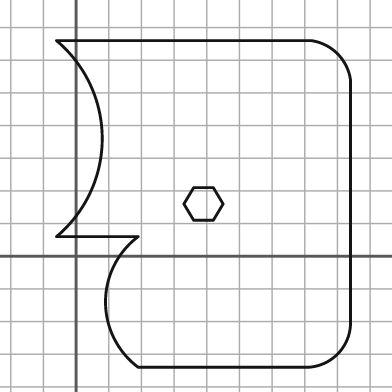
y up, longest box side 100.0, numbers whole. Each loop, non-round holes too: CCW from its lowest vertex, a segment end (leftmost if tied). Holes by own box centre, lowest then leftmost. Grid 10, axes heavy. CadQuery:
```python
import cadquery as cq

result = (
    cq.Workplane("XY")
    .moveTo(19.0, -34.0)
    .lineTo(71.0, -34.0)
    .threePointArc((80.0, -30.0), (84.0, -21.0))
    .lineTo(84.0, 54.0)
    .threePointArc((80.0, 62.0), (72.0, 66.0))
    .lineTo(-6.0, 66.0)
    .threePointArc((8.0, 36.0), (-6.0, 6.0))
    .lineTo(19.0, 6.0)
    .threePointArc((9.0, -14.0), (19.0, -34.0))
    .close()
    .moveTo(36.0, 11.0)
    .lineTo(42.0, 11.0)
    .lineTo(45.0, 16.0)
    .lineTo(42.0, 21.0)
    .lineTo(36.0, 21.0)
    .lineTo(33.0, 16.0)
    .close()
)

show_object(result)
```